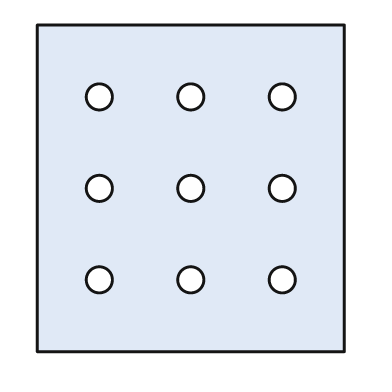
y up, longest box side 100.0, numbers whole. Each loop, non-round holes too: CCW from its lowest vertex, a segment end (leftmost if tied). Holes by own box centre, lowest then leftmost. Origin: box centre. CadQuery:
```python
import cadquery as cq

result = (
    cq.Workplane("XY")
    .moveTo(-47.0, -50.0)
    .lineTo(47.0, -50.0)
    .lineTo(47.0, 50.0)
    .lineTo(-47.0, 50.0)
    .close()
    .moveTo(-28.0, -28.0)
    .circle(4.0)
    .moveTo(0.0, -28.0)
    .circle(4.0)
    .moveTo(28.0, -28.0)
    .circle(4.0)
    .moveTo(-28.0, 0.0)
    .circle(4.0)
    .moveTo(0.0, 0.0)
    .circle(4.0)
    .moveTo(28.0, 0.0)
    .circle(4.0)
    .moveTo(-28.0, 28.0)
    .circle(4.0)
    .moveTo(0.0, 28.0)
    .circle(4.0)
    .moveTo(28.0, 28.0)
    .circle(4.0)
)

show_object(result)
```